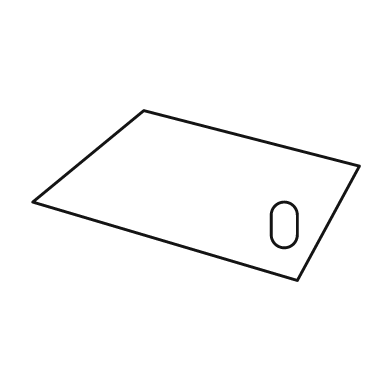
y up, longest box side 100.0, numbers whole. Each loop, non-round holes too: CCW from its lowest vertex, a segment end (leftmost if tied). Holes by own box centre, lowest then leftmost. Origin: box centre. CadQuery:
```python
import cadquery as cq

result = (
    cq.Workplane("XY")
    .moveTo(31.0, -26.0)
    .lineTo(50.0, 9.0)
    .lineTo(-16.0, 26.0)
    .lineTo(-50.0, -2.0)
    .close()
    .moveTo(23.0, -12.0)
    .threePointArc((27.0, -16.0), (31.0, -12.0))
    .lineTo(31.0, -6.0)
    .threePointArc((27.0, -2.0), (23.0, -6.0))
    .close()
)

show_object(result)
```